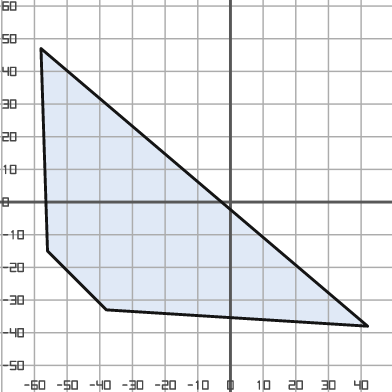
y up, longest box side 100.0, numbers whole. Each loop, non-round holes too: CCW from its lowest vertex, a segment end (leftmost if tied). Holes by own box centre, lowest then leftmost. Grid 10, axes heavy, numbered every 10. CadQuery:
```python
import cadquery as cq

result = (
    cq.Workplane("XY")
    .moveTo(42.0, -38.0)
    .lineTo(-58.0, 47.0)
    .lineTo(-56.0, -15.0)
    .lineTo(-38.0, -33.0)
    .close()
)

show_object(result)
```